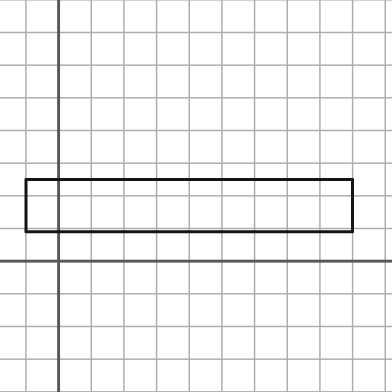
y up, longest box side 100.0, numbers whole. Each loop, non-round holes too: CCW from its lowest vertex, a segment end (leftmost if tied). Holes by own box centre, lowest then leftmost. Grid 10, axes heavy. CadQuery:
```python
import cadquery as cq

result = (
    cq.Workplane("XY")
    .moveTo(-10.0, 9.0)
    .lineTo(90.0, 9.0)
    .lineTo(90.0, 25.0)
    .lineTo(-10.0, 25.0)
    .close()
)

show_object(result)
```